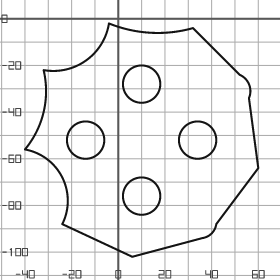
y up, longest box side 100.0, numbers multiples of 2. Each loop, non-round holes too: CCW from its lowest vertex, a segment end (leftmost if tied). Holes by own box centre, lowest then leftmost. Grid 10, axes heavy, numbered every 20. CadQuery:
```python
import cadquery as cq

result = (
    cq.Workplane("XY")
    .moveTo(6.0, -102.0)
    .lineTo(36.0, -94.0)
    .threePointArc((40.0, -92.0), (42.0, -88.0))
    .lineTo(60.0, -64.0)
    .lineTo(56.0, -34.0)
    .threePointArc((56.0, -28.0), (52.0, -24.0))
    .lineTo(32.0, -4.0)
    .threePointArc((14.0, -6.0), (-4.0, -2.0))
    .threePointArc((-14.0, -18.0), (-32.0, -22.0))
    .threePointArc((-32.0, -40.0), (-40.0, -56.0))
    .threePointArc((-24.0, -68.0), (-24.0, -88.0))
    .close()
    .moveTo(10.0, -76.0)
    .circle(8.0)
    .moveTo(-14.0, -52.0)
    .circle(8.0)
    .moveTo(34.0, -52.0)
    .circle(8.0)
    .moveTo(10.0, -28.0)
    .circle(8.0)
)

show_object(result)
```